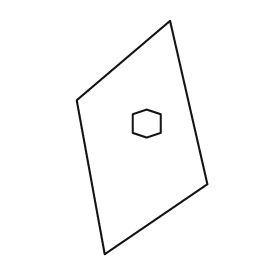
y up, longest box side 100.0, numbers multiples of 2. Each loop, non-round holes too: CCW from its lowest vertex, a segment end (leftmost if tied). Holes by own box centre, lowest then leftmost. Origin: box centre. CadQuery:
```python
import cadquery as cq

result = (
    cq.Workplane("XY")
    .moveTo(-16.0, -50.0)
    .lineTo(28.0, -20.0)
    .lineTo(12.0, 50.0)
    .lineTo(-28.0, 16.0)
    .close()
    .moveTo(2.0, 0.0)
    .lineTo(8.0, 2.0)
    .lineTo(8.0, 10.0)
    .lineTo(2.0, 12.0)
    .lineTo(-4.0, 10.0)
    .lineTo(-4.0, 2.0)
    .close()
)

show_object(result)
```